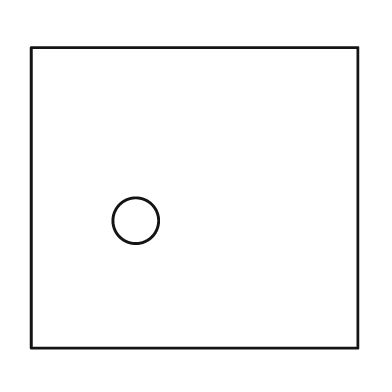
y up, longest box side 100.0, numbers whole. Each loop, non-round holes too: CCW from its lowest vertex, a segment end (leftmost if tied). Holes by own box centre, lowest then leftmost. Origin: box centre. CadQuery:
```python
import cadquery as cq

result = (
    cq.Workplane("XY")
    .moveTo(-50.0, -46.0)
    .lineTo(50.0, -46.0)
    .lineTo(50.0, 46.0)
    .lineTo(-50.0, 46.0)
    .close()
    .moveTo(-18.0, -7.0)
    .circle(7.0)
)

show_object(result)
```